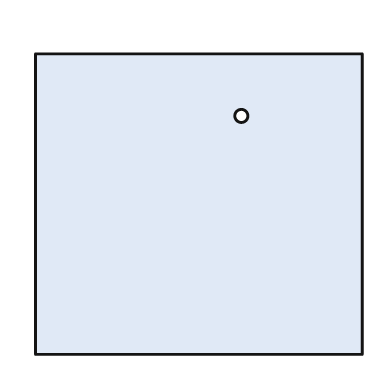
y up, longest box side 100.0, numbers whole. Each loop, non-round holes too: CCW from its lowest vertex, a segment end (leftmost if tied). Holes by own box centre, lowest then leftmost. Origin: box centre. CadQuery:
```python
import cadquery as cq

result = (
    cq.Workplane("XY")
    .moveTo(-50.0, -46.0)
    .lineTo(50.0, -46.0)
    .lineTo(50.0, 46.0)
    .lineTo(-50.0, 46.0)
    .close()
    .moveTo(13.0, 27.0)
    .circle(2.0)
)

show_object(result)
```